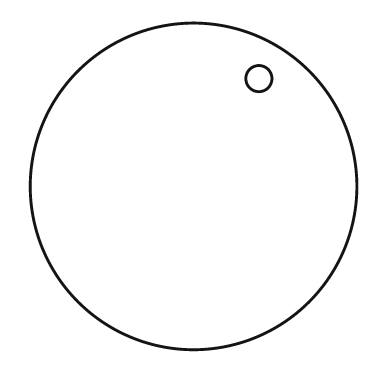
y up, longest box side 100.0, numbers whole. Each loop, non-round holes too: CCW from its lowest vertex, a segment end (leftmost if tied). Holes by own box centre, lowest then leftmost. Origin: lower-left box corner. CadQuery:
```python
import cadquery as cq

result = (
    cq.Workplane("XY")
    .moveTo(50.0, 50.0)
    .circle(50.0)
    .moveTo(70.0, 83.0)
    .circle(4.0)
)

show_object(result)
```